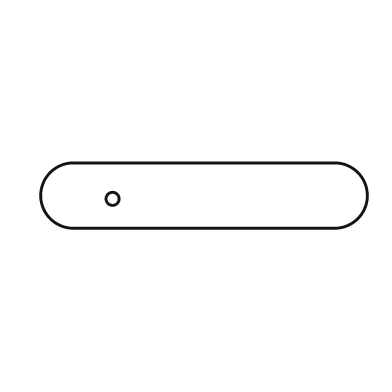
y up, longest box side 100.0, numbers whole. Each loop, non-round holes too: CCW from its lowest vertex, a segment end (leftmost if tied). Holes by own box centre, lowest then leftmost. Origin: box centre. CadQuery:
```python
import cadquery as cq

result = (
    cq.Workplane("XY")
    .moveTo(-40.0, -10.0)
    .lineTo(40.0, -10.0)
    .threePointArc((50.0, 0.0), (40.0, 10.0))
    .lineTo(-40.0, 10.0)
    .threePointArc((-50.0, 0.0), (-40.0, -10.0))
    .close()
    .moveTo(-28.0, -1.0)
    .circle(2.0)
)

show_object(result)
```